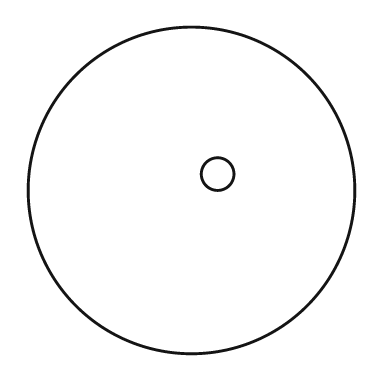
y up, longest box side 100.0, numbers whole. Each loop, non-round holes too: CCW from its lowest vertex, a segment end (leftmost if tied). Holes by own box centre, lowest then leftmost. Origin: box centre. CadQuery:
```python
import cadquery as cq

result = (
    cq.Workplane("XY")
    .moveTo(0.0, 0.0)
    .circle(50.0)
    .moveTo(8.0, 5.0)
    .circle(5.0)
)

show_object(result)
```